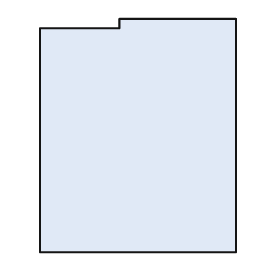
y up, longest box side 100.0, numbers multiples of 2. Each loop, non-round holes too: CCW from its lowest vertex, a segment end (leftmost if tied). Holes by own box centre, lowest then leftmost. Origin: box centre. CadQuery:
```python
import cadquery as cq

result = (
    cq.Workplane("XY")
    .moveTo(-42.0, -50.0)
    .lineTo(42.0, -50.0)
    .lineTo(42.0, 50.0)
    .lineTo(-8.0, 50.0)
    .lineTo(-8.0, 46.0)
    .lineTo(-42.0, 46.0)
    .close()
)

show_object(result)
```